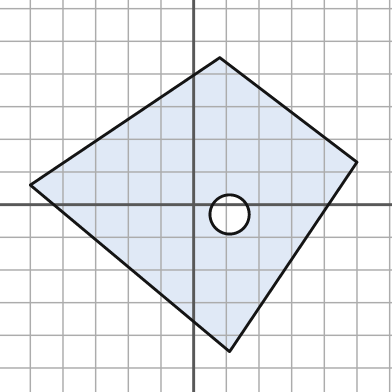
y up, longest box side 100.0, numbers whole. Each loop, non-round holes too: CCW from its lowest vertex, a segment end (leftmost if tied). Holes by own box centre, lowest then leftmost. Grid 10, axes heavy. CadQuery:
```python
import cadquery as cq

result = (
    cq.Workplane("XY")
    .moveTo(11.0, -45.0)
    .lineTo(50.0, 13.0)
    .lineTo(8.0, 45.0)
    .lineTo(-50.0, 6.0)
    .close()
    .moveTo(11.0, -3.0)
    .circle(6.0)
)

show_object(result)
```